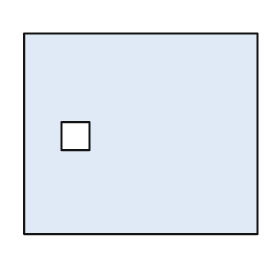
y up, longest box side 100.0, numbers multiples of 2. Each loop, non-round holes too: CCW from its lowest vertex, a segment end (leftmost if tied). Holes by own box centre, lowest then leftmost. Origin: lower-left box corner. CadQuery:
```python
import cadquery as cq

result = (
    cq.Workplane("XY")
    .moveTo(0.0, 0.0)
    .lineTo(100.0, 0.0)
    .lineTo(100.0, 86.0)
    .lineTo(0.0, 86.0)
    .close()
    .moveTo(16.0, 36.0)
    .lineTo(28.0, 36.0)
    .lineTo(28.0, 48.0)
    .lineTo(16.0, 48.0)
    .close()
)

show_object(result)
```